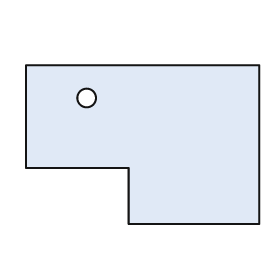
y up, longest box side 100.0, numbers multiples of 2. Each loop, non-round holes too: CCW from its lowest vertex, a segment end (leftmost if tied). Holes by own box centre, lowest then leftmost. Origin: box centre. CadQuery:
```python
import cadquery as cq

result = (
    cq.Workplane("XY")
    .moveTo(-6.0, -34.0)
    .lineTo(50.0, -34.0)
    .lineTo(50.0, 34.0)
    .lineTo(-50.0, 34.0)
    .lineTo(-50.0, -10.0)
    .lineTo(-6.0, -10.0)
    .close()
    .moveTo(-24.0, 20.0)
    .circle(4.0)
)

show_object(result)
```